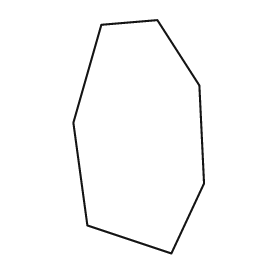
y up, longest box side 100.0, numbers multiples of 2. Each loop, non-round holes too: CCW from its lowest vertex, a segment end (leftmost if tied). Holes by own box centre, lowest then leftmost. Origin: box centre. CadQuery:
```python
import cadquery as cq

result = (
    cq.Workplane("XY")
    .moveTo(14.0, -50.0)
    .lineTo(28.0, -20.0)
    .lineTo(26.0, 22.0)
    .lineTo(8.0, 50.0)
    .lineTo(-16.0, 48.0)
    .lineTo(-28.0, 6.0)
    .lineTo(-22.0, -38.0)
    .close()
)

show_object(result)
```